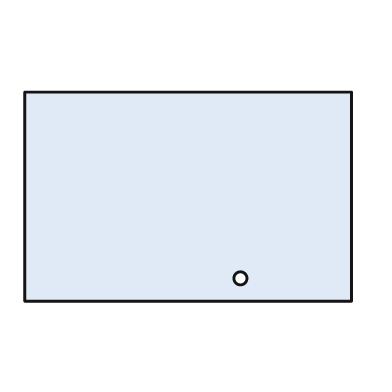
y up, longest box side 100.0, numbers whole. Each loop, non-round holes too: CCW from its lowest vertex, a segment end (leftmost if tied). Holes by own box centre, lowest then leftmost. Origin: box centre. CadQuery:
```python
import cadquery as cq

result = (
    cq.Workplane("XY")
    .moveTo(-50.0, -32.0)
    .lineTo(50.0, -32.0)
    .lineTo(50.0, 32.0)
    .lineTo(-50.0, 32.0)
    .close()
    .moveTo(16.0, -25.0)
    .circle(2.0)
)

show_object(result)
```